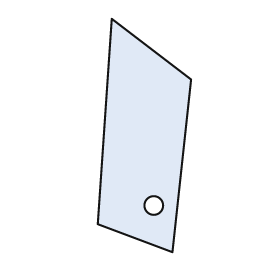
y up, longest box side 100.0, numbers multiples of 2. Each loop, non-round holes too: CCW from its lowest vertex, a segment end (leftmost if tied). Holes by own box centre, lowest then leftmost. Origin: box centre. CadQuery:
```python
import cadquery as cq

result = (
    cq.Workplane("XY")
    .moveTo(12.0, -50.0)
    .lineTo(20.0, 24.0)
    .lineTo(-14.0, 50.0)
    .lineTo(-20.0, -38.0)
    .close()
    .moveTo(4.0, -30.0)
    .circle(4.0)
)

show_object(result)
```